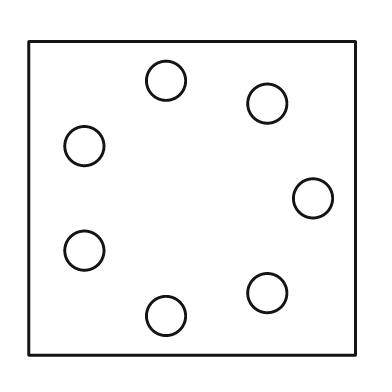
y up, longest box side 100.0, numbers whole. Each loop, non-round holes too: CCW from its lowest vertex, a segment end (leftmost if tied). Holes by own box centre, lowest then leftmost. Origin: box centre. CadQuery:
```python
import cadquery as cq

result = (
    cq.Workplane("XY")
    .moveTo(-50.0, -48.0)
    .lineTo(50.0, -48.0)
    .lineTo(50.0, 48.0)
    .lineTo(-50.0, 48.0)
    .close()
    .moveTo(-8.0, -36.0)
    .circle(6.0)
    .moveTo(23.0, -29.0)
    .circle(6.0)
    .moveTo(-33.0, -16.0)
    .circle(6.0)
    .moveTo(37.0, 0.0)
    .circle(6.0)
    .moveTo(-33.0, 16.0)
    .circle(6.0)
    .moveTo(23.0, 29.0)
    .circle(6.0)
    .moveTo(-8.0, 36.0)
    .circle(6.0)
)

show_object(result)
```